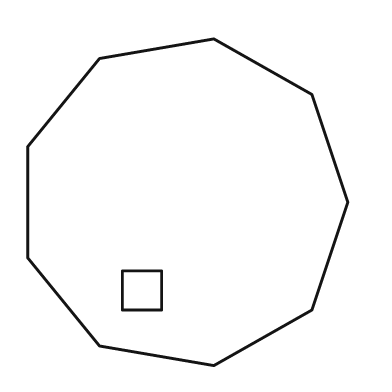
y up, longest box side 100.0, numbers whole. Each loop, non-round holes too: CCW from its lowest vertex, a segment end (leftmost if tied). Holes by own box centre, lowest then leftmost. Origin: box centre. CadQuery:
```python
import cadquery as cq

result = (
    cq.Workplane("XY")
    .moveTo(8.0, -50.0)
    .lineTo(38.0, -33.0)
    .lineTo(49.0, 0.0)
    .lineTo(38.0, 33.0)
    .lineTo(8.0, 50.0)
    .lineTo(-27.0, 44.0)
    .lineTo(-49.0, 17.0)
    .lineTo(-49.0, -17.0)
    .lineTo(-27.0, -44.0)
    .close()
    .moveTo(-20.0, -33.0)
    .lineTo(-8.0, -33.0)
    .lineTo(-8.0, -21.0)
    .lineTo(-20.0, -21.0)
    .close()
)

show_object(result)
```